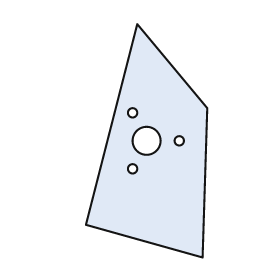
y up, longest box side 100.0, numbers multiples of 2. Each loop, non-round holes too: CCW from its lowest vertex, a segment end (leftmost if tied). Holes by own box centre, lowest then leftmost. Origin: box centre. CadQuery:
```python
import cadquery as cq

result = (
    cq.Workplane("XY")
    .moveTo(24.0, -50.0)
    .lineTo(26.0, 14.0)
    .lineTo(-4.0, 50.0)
    .lineTo(-26.0, -36.0)
    .close()
    .moveTo(-6.0, -12.0)
    .circle(2.0)
    .moveTo(0.0, 0.0)
    .circle(6.0)
    .moveTo(14.0, 0.0)
    .circle(2.0)
    .moveTo(-6.0, 12.0)
    .circle(2.0)
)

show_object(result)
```